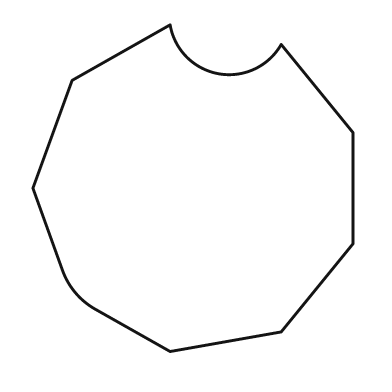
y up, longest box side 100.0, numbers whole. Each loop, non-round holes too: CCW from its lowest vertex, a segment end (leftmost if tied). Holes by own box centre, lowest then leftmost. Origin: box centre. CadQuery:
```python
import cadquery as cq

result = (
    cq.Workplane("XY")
    .moveTo(-7.0, -50.0)
    .lineTo(27.0, -44.0)
    .lineTo(49.0, -17.0)
    .lineTo(49.0, 17.0)
    .lineTo(27.0, 44.0)
    .threePointArc((8.0, 35.0), (-7.0, 50.0))
    .lineTo(-37.0, 33.0)
    .lineTo(-49.0, 0.0)
    .lineTo(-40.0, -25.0)
    .threePointArc((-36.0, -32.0), (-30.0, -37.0))
    .close()
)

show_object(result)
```